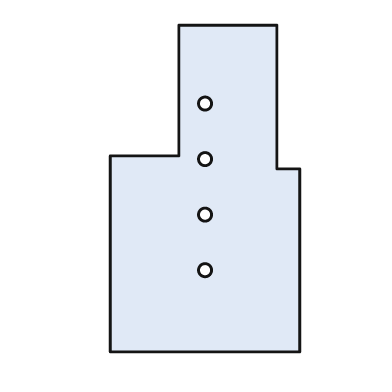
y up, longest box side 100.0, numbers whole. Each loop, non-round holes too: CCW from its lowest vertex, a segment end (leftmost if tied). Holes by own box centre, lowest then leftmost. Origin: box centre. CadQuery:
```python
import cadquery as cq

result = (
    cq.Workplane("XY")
    .moveTo(-29.0, -50.0)
    .lineTo(29.0, -50.0)
    .lineTo(29.0, 6.0)
    .lineTo(22.0, 6.0)
    .lineTo(22.0, 50.0)
    .lineTo(-8.0, 50.0)
    .lineTo(-8.0, 10.0)
    .lineTo(-29.0, 10.0)
    .close()
    .moveTo(0.0, -25.0)
    .circle(2.0)
    .moveTo(0.0, -8.0)
    .circle(2.0)
    .moveTo(0.0, 9.0)
    .circle(2.0)
    .moveTo(0.0, 26.0)
    .circle(2.0)
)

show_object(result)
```